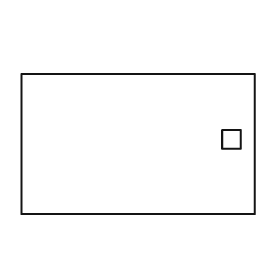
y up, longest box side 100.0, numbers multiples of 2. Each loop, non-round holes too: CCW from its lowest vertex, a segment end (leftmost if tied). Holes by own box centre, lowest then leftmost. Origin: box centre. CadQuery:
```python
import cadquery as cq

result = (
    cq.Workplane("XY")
    .moveTo(-50.0, -30.0)
    .lineTo(50.0, -30.0)
    .lineTo(50.0, 30.0)
    .lineTo(-50.0, 30.0)
    .close()
    .moveTo(36.0, -2.0)
    .lineTo(44.0, -2.0)
    .lineTo(44.0, 6.0)
    .lineTo(36.0, 6.0)
    .close()
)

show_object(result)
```